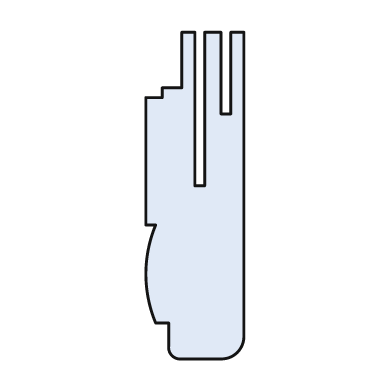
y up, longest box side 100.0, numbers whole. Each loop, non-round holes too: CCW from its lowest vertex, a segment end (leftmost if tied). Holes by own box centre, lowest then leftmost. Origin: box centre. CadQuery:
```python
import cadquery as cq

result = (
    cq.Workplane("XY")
    .moveTo(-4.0, -50.0)
    .lineTo(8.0, -50.0)
    .threePointArc((13.0, -48.0), (15.0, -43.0))
    .lineTo(15.0, 50.0)
    .lineTo(11.0, 50.0)
    .lineTo(11.0, 25.0)
    .lineTo(8.0, 25.0)
    .lineTo(8.0, 50.0)
    .lineTo(3.0, 50.0)
    .lineTo(3.0, 3.0)
    .lineTo(0.0, 3.0)
    .lineTo(0.0, 50.0)
    .lineTo(-4.0, 50.0)
    .lineTo(-4.0, 33.0)
    .lineTo(-10.0, 33.0)
    .lineTo(-10.0, 30.0)
    .lineTo(-15.0, 30.0)
    .lineTo(-15.0, -9.0)
    .lineTo(-12.0, -9.0)
    .threePointArc((-15.0, -24.0), (-12.0, -39.0))
    .lineTo(-8.0, -39.0)
    .lineTo(-8.0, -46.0)
    .threePointArc((-7.0, -49.0), (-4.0, -50.0))
    .close()
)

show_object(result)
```